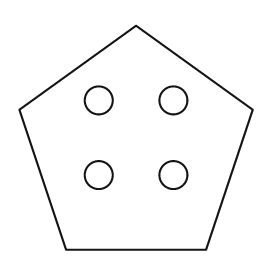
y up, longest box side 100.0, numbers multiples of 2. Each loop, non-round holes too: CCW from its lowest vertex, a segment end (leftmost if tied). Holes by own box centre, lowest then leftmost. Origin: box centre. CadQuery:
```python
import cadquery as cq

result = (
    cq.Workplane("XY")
    .moveTo(-30.0, -48.0)
    .lineTo(30.0, -48.0)
    .lineTo(50.0, 12.0)
    .lineTo(0.0, 48.0)
    .lineTo(-50.0, 12.0)
    .close()
    .moveTo(-16.0, -16.0)
    .circle(6.0)
    .moveTo(16.0, -16.0)
    .circle(6.0)
    .moveTo(-16.0, 16.0)
    .circle(6.0)
    .moveTo(16.0, 16.0)
    .circle(6.0)
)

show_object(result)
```